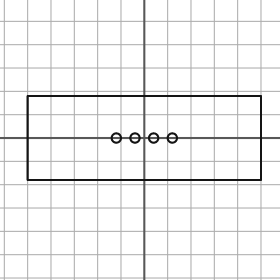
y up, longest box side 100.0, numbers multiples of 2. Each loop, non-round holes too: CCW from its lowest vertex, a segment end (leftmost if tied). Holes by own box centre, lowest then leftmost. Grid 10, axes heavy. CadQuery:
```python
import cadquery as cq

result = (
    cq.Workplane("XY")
    .moveTo(-50.0, -18.0)
    .lineTo(50.0, -18.0)
    .lineTo(50.0, 18.0)
    .lineTo(-50.0, 18.0)
    .close()
    .moveTo(-12.0, 0.0)
    .circle(2.0)
    .moveTo(-4.0, 0.0)
    .circle(2.0)
    .moveTo(4.0, 0.0)
    .circle(2.0)
    .moveTo(12.0, 0.0)
    .circle(2.0)
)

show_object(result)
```